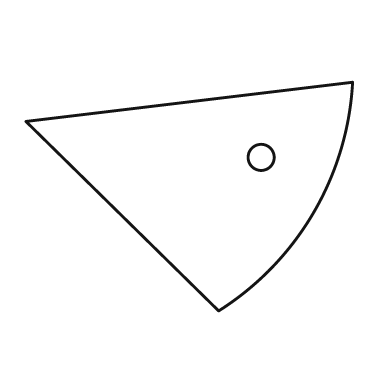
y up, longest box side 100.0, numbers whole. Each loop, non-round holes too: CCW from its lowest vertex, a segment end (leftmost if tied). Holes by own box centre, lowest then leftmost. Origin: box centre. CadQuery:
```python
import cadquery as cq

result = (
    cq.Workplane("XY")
    .moveTo(9.0, -35.0)
    .threePointArc((38.0, -5.0), (50.0, 35.0))
    .lineTo(-50.0, 23.0)
    .close()
    .moveTo(22.0, 12.0)
    .circle(4.0)
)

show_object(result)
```